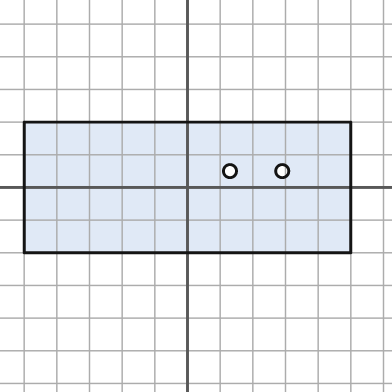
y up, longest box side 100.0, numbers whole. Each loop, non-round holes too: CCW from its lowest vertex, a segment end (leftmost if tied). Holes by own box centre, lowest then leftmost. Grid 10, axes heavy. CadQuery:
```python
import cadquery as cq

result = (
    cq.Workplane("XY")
    .moveTo(-50.0, -20.0)
    .lineTo(50.0, -20.0)
    .lineTo(50.0, 20.0)
    .lineTo(-50.0, 20.0)
    .close()
    .moveTo(13.0, 5.0)
    .circle(2.0)
    .moveTo(29.0, 5.0)
    .circle(2.0)
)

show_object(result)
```